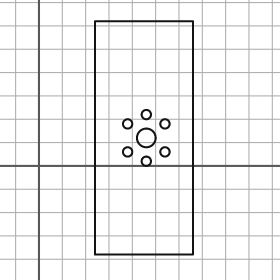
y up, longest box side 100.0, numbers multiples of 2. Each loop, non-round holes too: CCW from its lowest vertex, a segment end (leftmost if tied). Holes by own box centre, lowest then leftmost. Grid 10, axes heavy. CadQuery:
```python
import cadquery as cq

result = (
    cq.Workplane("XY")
    .moveTo(24.0, -38.0)
    .lineTo(66.0, -38.0)
    .lineTo(66.0, 62.0)
    .lineTo(24.0, 62.0)
    .close()
    .moveTo(46.0, 2.0)
    .circle(2.0)
    .moveTo(38.0, 6.0)
    .circle(2.0)
    .moveTo(54.0, 6.0)
    .circle(2.0)
    .moveTo(46.0, 12.0)
    .circle(4.0)
    .moveTo(38.0, 18.0)
    .circle(2.0)
    .moveTo(54.0, 18.0)
    .circle(2.0)
    .moveTo(46.0, 22.0)
    .circle(2.0)
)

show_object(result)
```